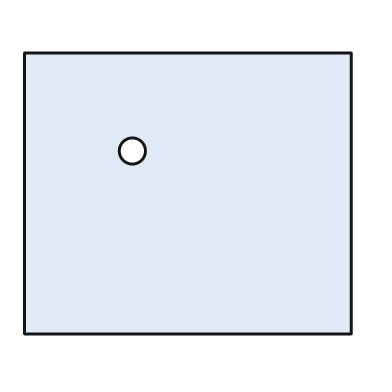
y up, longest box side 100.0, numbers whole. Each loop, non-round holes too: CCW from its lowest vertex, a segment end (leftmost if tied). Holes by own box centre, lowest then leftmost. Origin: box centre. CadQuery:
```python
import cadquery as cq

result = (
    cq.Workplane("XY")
    .moveTo(-50.0, -43.0)
    .lineTo(50.0, -43.0)
    .lineTo(50.0, 43.0)
    .lineTo(-50.0, 43.0)
    .close()
    .moveTo(-17.0, 13.0)
    .circle(4.0)
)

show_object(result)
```